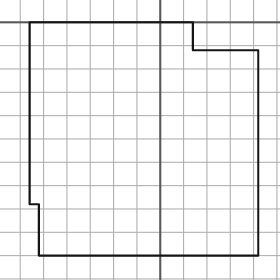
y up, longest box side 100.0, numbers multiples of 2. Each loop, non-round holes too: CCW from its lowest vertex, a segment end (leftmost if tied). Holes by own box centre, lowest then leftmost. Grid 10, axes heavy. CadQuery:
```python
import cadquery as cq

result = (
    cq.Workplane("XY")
    .moveTo(-52.0, -100.0)
    .lineTo(42.0, -100.0)
    .lineTo(42.0, -12.0)
    .lineTo(14.0, -12.0)
    .lineTo(14.0, 0.0)
    .lineTo(-56.0, 0.0)
    .lineTo(-56.0, -78.0)
    .lineTo(-52.0, -78.0)
    .close()
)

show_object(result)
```